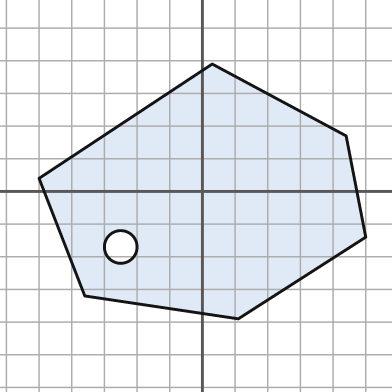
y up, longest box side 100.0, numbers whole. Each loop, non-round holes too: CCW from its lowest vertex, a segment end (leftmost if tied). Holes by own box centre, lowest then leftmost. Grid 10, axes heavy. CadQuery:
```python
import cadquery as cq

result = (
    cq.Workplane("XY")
    .moveTo(11.0, -39.0)
    .lineTo(50.0, -14.0)
    .lineTo(44.0, 17.0)
    .lineTo(3.0, 39.0)
    .lineTo(-50.0, 4.0)
    .lineTo(-36.0, -32.0)
    .close()
    .moveTo(-25.0, -17.0)
    .circle(5.0)
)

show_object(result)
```